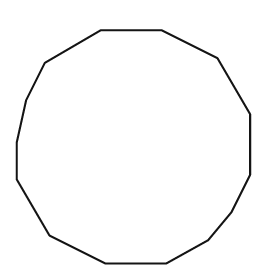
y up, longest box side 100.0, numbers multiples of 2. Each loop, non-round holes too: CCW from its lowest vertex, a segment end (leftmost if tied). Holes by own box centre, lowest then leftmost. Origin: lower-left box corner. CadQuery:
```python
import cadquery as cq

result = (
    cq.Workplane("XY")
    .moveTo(38.0, 0.0)
    .lineTo(64.0, 0.0)
    .lineTo(82.0, 10.0)
    .lineTo(92.0, 22.0)
    .lineTo(100.0, 38.0)
    .lineTo(100.0, 64.0)
    .lineTo(86.0, 88.0)
    .lineTo(62.0, 100.0)
    .lineTo(36.0, 100.0)
    .lineTo(12.0, 86.0)
    .lineTo(4.0, 70.0)
    .lineTo(0.0, 52.0)
    .lineTo(0.0, 36.0)
    .lineTo(14.0, 12.0)
    .close()
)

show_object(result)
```